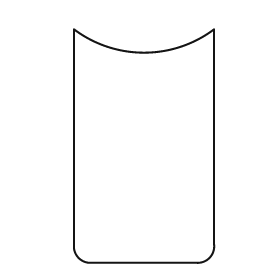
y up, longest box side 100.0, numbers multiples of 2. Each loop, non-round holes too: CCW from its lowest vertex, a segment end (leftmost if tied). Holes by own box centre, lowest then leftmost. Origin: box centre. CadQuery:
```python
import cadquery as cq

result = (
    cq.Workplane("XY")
    .moveTo(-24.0, -50.0)
    .lineTo(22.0, -50.0)
    .threePointArc((28.0, -48.0), (30.0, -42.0))
    .lineTo(30.0, 50.0)
    .threePointArc((0.0, 40.0), (-30.0, 50.0))
    .lineTo(-30.0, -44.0)
    .threePointArc((-28.0, -48.0), (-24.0, -50.0))
    .close()
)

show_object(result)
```